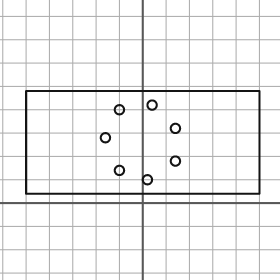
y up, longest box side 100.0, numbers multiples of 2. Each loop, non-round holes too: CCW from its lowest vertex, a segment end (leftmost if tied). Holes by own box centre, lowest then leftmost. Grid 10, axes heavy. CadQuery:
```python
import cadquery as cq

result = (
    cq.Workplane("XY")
    .moveTo(-50.0, 4.0)
    .lineTo(50.0, 4.0)
    .lineTo(50.0, 48.0)
    .lineTo(-50.0, 48.0)
    .close()
    .moveTo(2.0, 10.0)
    .circle(2.0)
    .moveTo(-10.0, 14.0)
    .circle(2.0)
    .moveTo(14.0, 18.0)
    .circle(2.0)
    .moveTo(-16.0, 28.0)
    .circle(2.0)
    .moveTo(14.0, 32.0)
    .circle(2.0)
    .moveTo(-10.0, 40.0)
    .circle(2.0)
    .moveTo(4.0, 42.0)
    .circle(2.0)
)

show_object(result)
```